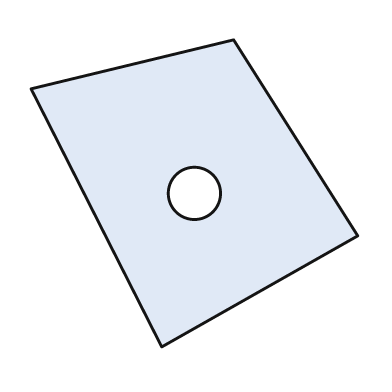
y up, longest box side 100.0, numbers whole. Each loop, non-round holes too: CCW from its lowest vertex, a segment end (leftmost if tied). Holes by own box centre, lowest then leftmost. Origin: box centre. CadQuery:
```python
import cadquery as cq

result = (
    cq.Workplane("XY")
    .moveTo(-10.0, -47.0)
    .lineTo(50.0, -13.0)
    .lineTo(12.0, 47.0)
    .lineTo(-50.0, 32.0)
    .close()
    .moveTo(0.0, 0.0)
    .circle(8.0)
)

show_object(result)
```